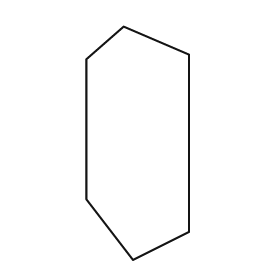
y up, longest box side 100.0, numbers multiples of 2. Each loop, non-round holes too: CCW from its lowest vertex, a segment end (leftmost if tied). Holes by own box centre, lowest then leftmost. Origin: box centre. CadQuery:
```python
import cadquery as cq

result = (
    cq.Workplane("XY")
    .moveTo(-2.0, -50.0)
    .lineTo(22.0, -38.0)
    .lineTo(22.0, 38.0)
    .lineTo(-6.0, 50.0)
    .lineTo(-22.0, 36.0)
    .lineTo(-22.0, -24.0)
    .close()
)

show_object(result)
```